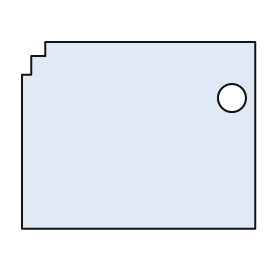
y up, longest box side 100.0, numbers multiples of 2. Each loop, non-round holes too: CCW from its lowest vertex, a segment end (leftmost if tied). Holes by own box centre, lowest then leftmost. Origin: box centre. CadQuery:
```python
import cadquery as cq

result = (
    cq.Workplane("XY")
    .moveTo(-50.0, -40.0)
    .lineTo(50.0, -40.0)
    .lineTo(50.0, 40.0)
    .lineTo(-40.0, 40.0)
    .lineTo(-40.0, 34.0)
    .lineTo(-46.0, 34.0)
    .lineTo(-46.0, 26.0)
    .lineTo(-50.0, 26.0)
    .close()
    .moveTo(40.0, 16.0)
    .circle(6.0)
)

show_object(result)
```